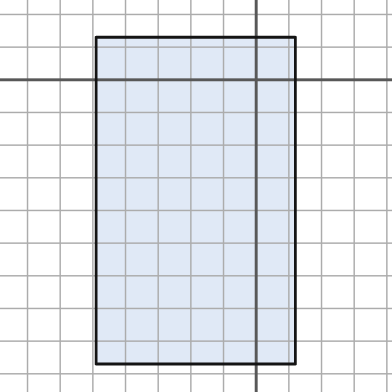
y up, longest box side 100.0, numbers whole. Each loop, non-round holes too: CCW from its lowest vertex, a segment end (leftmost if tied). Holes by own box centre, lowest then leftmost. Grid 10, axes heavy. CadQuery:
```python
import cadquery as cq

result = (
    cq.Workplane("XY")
    .moveTo(-49.0, -87.0)
    .lineTo(12.0, -87.0)
    .lineTo(12.0, 13.0)
    .lineTo(-49.0, 13.0)
    .close()
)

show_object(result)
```